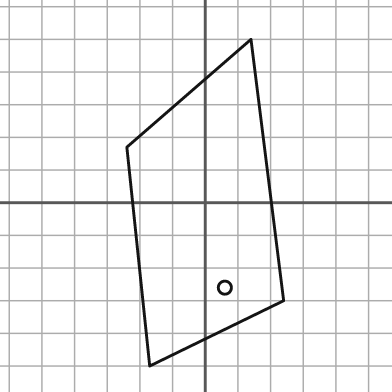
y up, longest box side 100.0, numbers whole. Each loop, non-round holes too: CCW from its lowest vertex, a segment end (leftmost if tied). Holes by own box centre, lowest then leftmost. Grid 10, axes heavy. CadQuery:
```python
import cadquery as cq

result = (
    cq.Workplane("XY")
    .moveTo(-17.0, -50.0)
    .lineTo(24.0, -30.0)
    .lineTo(14.0, 50.0)
    .lineTo(-24.0, 17.0)
    .close()
    .moveTo(6.0, -26.0)
    .circle(2.0)
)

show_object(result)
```